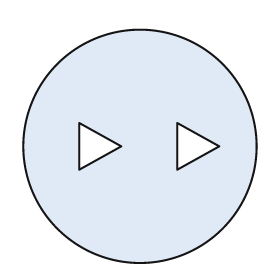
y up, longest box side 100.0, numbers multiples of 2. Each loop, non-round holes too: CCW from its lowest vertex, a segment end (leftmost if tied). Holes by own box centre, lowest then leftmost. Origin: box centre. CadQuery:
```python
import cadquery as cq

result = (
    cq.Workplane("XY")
    .moveTo(0.0, 0.0)
    .circle(50.0)
    .moveTo(-26.0, -10.0)
    .lineTo(-8.0, 0.0)
    .lineTo(-26.0, 10.0)
    .close()
    .moveTo(16.0, -10.0)
    .lineTo(34.0, 0.0)
    .lineTo(16.0, 10.0)
    .close()
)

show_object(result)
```